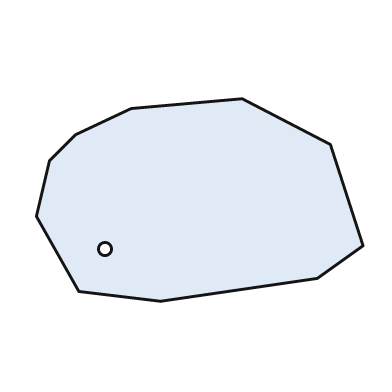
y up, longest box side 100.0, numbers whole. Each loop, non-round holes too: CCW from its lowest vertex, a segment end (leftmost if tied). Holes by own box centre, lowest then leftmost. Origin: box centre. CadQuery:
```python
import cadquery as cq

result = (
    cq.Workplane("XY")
    .moveTo(-12.0, -31.0)
    .lineTo(36.0, -24.0)
    .lineTo(50.0, -14.0)
    .lineTo(40.0, 17.0)
    .lineTo(13.0, 31.0)
    .lineTo(-21.0, 28.0)
    .lineTo(-38.0, 20.0)
    .lineTo(-46.0, 12.0)
    .lineTo(-50.0, -5.0)
    .lineTo(-37.0, -28.0)
    .close()
    .moveTo(-29.0, -15.0)
    .circle(2.0)
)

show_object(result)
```